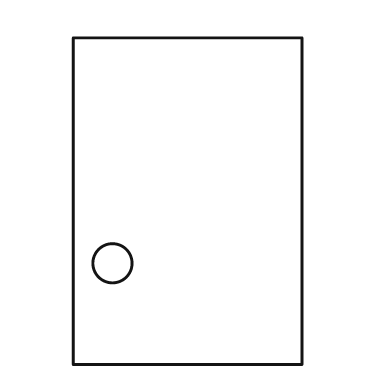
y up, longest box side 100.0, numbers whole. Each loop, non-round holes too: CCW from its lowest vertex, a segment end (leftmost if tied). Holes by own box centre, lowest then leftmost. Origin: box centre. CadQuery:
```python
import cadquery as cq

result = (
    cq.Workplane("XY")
    .moveTo(-35.0, -50.0)
    .lineTo(35.0, -50.0)
    .lineTo(35.0, 50.0)
    .lineTo(-35.0, 50.0)
    .close()
    .moveTo(-23.0, -19.0)
    .circle(6.0)
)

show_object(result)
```